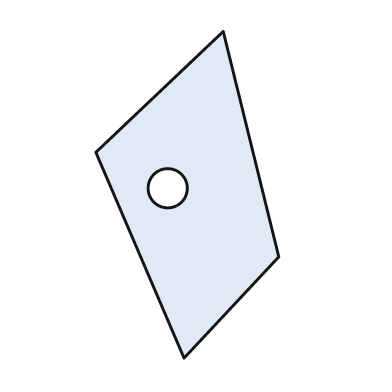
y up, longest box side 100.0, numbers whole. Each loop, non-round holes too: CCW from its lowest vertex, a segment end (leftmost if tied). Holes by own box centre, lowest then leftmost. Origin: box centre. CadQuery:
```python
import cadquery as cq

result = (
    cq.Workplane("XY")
    .moveTo(-1.0, -50.0)
    .lineTo(28.0, -19.0)
    .lineTo(11.0, 50.0)
    .lineTo(-28.0, 13.0)
    .close()
    .moveTo(-6.0, 2.0)
    .circle(6.0)
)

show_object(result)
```